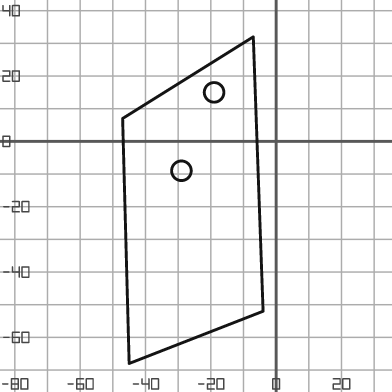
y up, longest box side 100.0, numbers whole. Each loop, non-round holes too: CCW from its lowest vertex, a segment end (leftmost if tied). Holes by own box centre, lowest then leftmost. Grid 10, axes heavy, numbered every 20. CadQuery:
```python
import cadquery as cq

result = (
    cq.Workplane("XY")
    .moveTo(-45.0, -68.0)
    .lineTo(-4.0, -52.0)
    .lineTo(-7.0, 32.0)
    .lineTo(-47.0, 7.0)
    .close()
    .moveTo(-29.0, -9.0)
    .circle(3.0)
    .moveTo(-19.0, 15.0)
    .circle(3.0)
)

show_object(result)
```